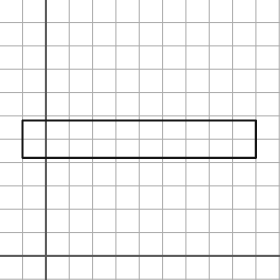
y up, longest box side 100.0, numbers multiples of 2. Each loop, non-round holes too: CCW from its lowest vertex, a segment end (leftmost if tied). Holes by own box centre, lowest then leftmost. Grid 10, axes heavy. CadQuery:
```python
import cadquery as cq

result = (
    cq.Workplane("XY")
    .moveTo(-10.0, 42.0)
    .lineTo(90.0, 42.0)
    .lineTo(90.0, 58.0)
    .lineTo(-10.0, 58.0)
    .close()
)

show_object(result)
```